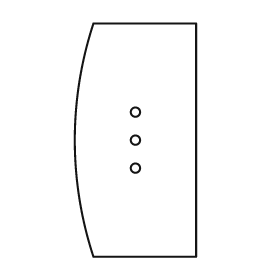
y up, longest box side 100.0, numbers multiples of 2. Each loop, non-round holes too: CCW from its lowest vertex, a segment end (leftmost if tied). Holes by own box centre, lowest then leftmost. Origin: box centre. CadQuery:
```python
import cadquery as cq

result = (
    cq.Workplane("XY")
    .moveTo(-18.0, -50.0)
    .lineTo(26.0, -50.0)
    .lineTo(26.0, 50.0)
    .lineTo(-18.0, 50.0)
    .threePointArc((-26.0, 0.0), (-18.0, -50.0))
    .close()
    .moveTo(0.0, -12.0)
    .circle(2.0)
    .moveTo(0.0, 0.0)
    .circle(2.0)
    .moveTo(0.0, 12.0)
    .circle(2.0)
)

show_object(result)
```